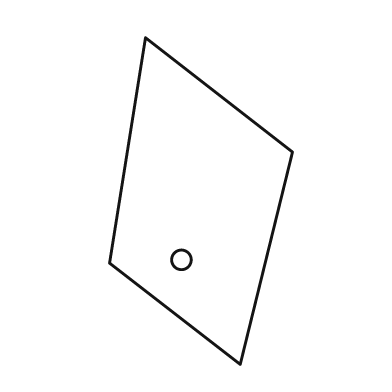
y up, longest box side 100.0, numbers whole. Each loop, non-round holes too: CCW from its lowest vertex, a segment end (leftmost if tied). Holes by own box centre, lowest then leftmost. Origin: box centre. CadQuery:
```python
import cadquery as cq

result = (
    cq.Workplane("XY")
    .moveTo(12.0, -50.0)
    .lineTo(28.0, 15.0)
    .lineTo(-17.0, 50.0)
    .lineTo(-28.0, -19.0)
    .close()
    .moveTo(-6.0, -18.0)
    .circle(3.0)
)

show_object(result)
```